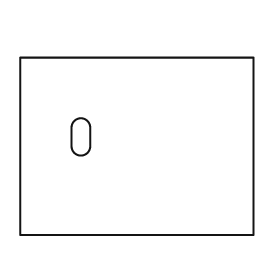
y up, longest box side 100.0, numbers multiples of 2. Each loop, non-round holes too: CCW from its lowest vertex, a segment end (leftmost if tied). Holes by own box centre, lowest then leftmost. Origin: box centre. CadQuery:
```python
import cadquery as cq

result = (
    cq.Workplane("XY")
    .moveTo(-50.0, -38.0)
    .lineTo(50.0, -38.0)
    .lineTo(50.0, 38.0)
    .lineTo(-50.0, 38.0)
    .close()
    .moveTo(-28.0, 0.0)
    .threePointArc((-24.0, -4.0), (-20.0, 0.0))
    .lineTo(-20.0, 8.0)
    .threePointArc((-24.0, 12.0), (-28.0, 8.0))
    .close()
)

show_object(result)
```